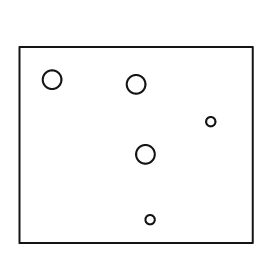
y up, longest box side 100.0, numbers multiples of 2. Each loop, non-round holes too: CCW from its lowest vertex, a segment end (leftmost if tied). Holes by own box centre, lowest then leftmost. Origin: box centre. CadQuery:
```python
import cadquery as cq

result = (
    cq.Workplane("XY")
    .moveTo(-50.0, -42.0)
    .lineTo(50.0, -42.0)
    .lineTo(50.0, 42.0)
    .lineTo(-50.0, 42.0)
    .close()
    .moveTo(6.0, -32.0)
    .circle(2.0)
    .moveTo(4.0, -4.0)
    .circle(4.0)
    .moveTo(32.0, 10.0)
    .circle(2.0)
    .moveTo(0.0, 26.0)
    .circle(4.0)
    .moveTo(-36.0, 28.0)
    .circle(4.0)
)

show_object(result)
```